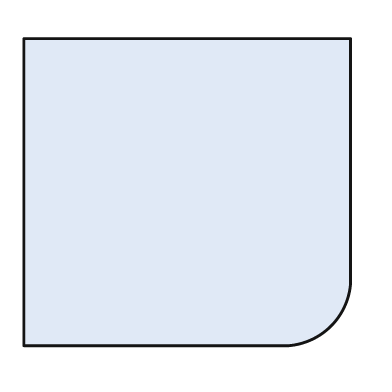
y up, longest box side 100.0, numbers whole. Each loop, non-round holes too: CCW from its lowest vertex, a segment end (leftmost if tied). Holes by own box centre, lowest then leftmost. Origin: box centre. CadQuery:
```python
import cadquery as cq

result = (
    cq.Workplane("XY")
    .moveTo(-50.0, -47.0)
    .lineTo(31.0, -47.0)
    .threePointArc((44.0, -41.0), (50.0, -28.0))
    .lineTo(50.0, 47.0)
    .lineTo(-50.0, 47.0)
    .close()
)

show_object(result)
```